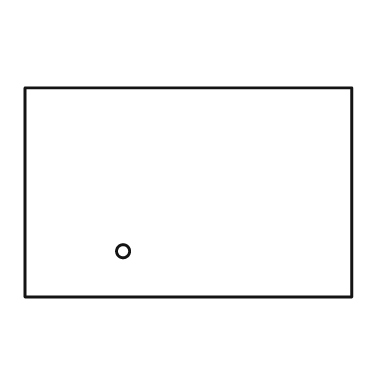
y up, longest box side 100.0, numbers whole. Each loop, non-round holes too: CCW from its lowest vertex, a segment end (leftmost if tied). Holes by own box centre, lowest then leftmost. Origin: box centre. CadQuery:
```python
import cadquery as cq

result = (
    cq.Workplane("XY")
    .moveTo(-50.0, -32.0)
    .lineTo(50.0, -32.0)
    .lineTo(50.0, 32.0)
    .lineTo(-50.0, 32.0)
    .close()
    .moveTo(-20.0, -18.0)
    .circle(2.0)
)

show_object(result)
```